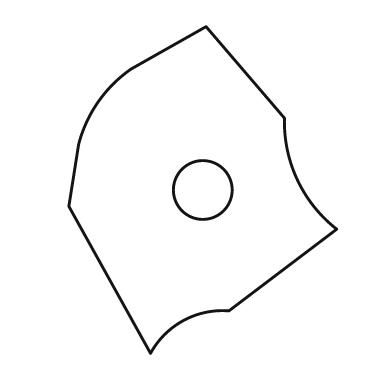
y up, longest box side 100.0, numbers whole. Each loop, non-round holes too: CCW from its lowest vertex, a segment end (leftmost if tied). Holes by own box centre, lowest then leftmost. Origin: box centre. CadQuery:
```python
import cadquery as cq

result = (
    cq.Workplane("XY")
    .moveTo(-16.0, -50.0)
    .threePointArc((-6.0, -40.0), (8.0, -37.0))
    .lineTo(41.0, -12.0)
    .threePointArc((29.0, 3.0), (25.0, 22.0))
    .lineTo(1.0, 50.0)
    .lineTo(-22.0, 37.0)
    .threePointArc((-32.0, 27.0), (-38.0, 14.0))
    .lineTo(-41.0, -5.0)
    .close()
    .moveTo(0.0, 0.0)
    .circle(9.0)
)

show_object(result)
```